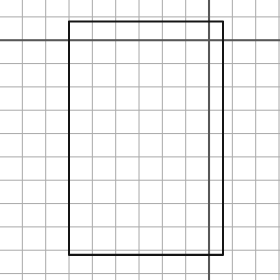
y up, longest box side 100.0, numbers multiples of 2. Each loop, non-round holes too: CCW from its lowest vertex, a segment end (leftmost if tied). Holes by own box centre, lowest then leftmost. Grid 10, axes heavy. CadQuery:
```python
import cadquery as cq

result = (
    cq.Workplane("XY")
    .moveTo(-60.0, -92.0)
    .lineTo(6.0, -92.0)
    .lineTo(6.0, 8.0)
    .lineTo(-60.0, 8.0)
    .close()
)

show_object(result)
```